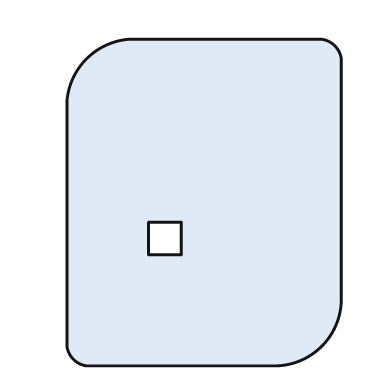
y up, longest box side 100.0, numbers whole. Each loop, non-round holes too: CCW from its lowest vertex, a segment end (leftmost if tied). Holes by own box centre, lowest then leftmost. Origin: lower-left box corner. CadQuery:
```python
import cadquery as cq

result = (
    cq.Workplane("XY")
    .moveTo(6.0, 0.0)
    .lineTo(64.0, 0.0)
    .threePointArc((78.0, 6.0), (84.0, 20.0))
    .lineTo(84.0, 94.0)
    .threePointArc((82.0, 98.0), (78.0, 100.0))
    .lineTo(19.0, 100.0)
    .threePointArc((6.0, 94.0), (0.0, 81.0))
    .lineTo(0.0, 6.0)
    .threePointArc((2.0, 2.0), (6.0, 0.0))
    .close()
    .moveTo(25.0, 34.0)
    .lineTo(35.0, 34.0)
    .lineTo(35.0, 44.0)
    .lineTo(25.0, 44.0)
    .close()
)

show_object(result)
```